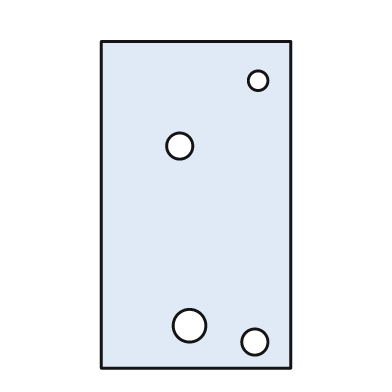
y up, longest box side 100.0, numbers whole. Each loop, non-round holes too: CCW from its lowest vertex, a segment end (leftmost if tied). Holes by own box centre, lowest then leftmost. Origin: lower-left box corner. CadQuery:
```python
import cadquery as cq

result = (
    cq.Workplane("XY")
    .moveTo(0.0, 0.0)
    .lineTo(58.0, 0.0)
    .lineTo(58.0, 100.0)
    .lineTo(0.0, 100.0)
    .close()
    .moveTo(47.0, 8.0)
    .circle(4.0)
    .moveTo(27.0, 13.0)
    .circle(5.0)
    .moveTo(24.0, 68.0)
    .circle(4.0)
    .moveTo(48.0, 88.0)
    .circle(3.0)
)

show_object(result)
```